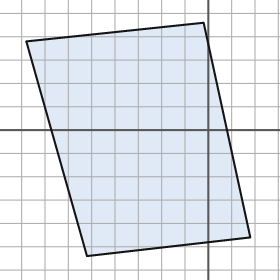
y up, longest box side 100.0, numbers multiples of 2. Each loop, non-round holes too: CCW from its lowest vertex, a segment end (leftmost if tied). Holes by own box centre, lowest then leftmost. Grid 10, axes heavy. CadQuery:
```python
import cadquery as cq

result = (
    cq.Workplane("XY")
    .moveTo(-52.0, -54.0)
    .lineTo(18.0, -46.0)
    .lineTo(-2.0, 46.0)
    .lineTo(-78.0, 38.0)
    .close()
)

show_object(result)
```